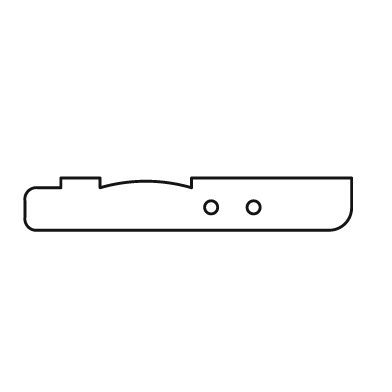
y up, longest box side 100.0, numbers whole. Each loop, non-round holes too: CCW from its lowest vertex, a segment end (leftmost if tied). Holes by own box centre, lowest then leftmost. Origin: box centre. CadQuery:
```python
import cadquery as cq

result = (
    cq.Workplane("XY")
    .moveTo(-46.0, -8.0)
    .lineTo(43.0, -8.0)
    .threePointArc((48.0, -6.0), (50.0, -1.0))
    .lineTo(50.0, 8.0)
    .lineTo(1.0, 8.0)
    .lineTo(1.0, 5.0)
    .threePointArc((-13.0, 7.0), (-27.0, 5.0))
    .lineTo(-27.0, 8.0)
    .lineTo(-39.0, 8.0)
    .lineTo(-39.0, 5.0)
    .lineTo(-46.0, 5.0)
    .threePointArc((-49.0, 4.0), (-50.0, 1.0))
    .lineTo(-50.0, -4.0)
    .threePointArc((-49.0, -7.0), (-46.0, -8.0))
    .close()
    .moveTo(7.0, -1.0)
    .circle(2.0)
    .moveTo(20.0, -1.0)
    .circle(2.0)
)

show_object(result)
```